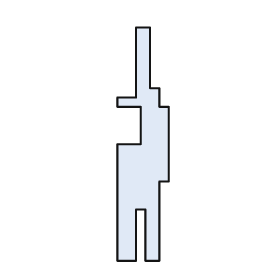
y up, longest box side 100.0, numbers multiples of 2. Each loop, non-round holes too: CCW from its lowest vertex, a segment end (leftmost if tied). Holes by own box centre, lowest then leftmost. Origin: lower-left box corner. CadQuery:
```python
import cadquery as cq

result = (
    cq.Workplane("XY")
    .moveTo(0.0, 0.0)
    .lineTo(8.0, 0.0)
    .lineTo(8.0, 22.0)
    .lineTo(12.0, 22.0)
    .lineTo(12.0, 0.0)
    .lineTo(18.0, 0.0)
    .lineTo(18.0, 34.0)
    .lineTo(22.0, 34.0)
    .lineTo(22.0, 66.0)
    .lineTo(18.0, 66.0)
    .lineTo(18.0, 74.0)
    .lineTo(14.0, 74.0)
    .lineTo(14.0, 100.0)
    .lineTo(8.0, 100.0)
    .lineTo(8.0, 70.0)
    .lineTo(0.0, 70.0)
    .lineTo(0.0, 66.0)
    .lineTo(10.0, 66.0)
    .lineTo(10.0, 50.0)
    .lineTo(0.0, 50.0)
    .close()
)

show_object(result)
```